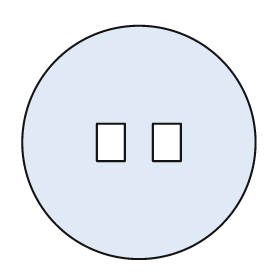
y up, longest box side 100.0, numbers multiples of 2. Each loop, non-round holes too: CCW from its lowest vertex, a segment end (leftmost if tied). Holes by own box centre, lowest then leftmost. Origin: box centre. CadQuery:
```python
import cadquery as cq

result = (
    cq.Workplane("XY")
    .moveTo(0.0, 0.0)
    .circle(50.0)
    .moveTo(-18.0, -8.0)
    .lineTo(-6.0, -8.0)
    .lineTo(-6.0, 8.0)
    .lineTo(-18.0, 8.0)
    .close()
    .moveTo(6.0, -8.0)
    .lineTo(18.0, -8.0)
    .lineTo(18.0, 8.0)
    .lineTo(6.0, 8.0)
    .close()
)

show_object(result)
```